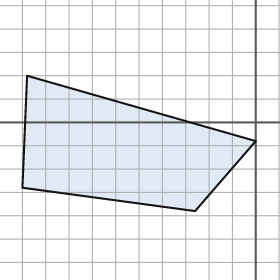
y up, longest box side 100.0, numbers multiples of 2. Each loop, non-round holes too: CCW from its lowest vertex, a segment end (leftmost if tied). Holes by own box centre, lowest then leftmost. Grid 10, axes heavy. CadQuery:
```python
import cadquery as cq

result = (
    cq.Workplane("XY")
    .moveTo(-26.0, -38.0)
    .lineTo(0.0, -8.0)
    .lineTo(-98.0, 20.0)
    .lineTo(-100.0, -28.0)
    .close()
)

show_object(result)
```